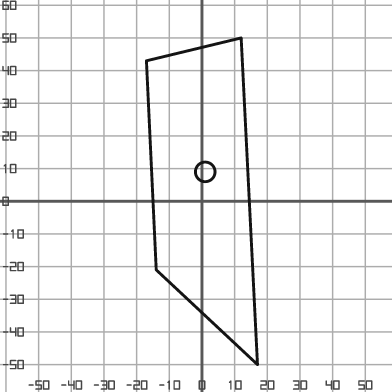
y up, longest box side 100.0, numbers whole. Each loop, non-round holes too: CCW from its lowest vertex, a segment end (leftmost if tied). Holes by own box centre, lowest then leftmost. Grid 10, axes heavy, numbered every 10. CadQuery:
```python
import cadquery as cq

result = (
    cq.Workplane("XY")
    .moveTo(17.0, -50.0)
    .lineTo(12.0, 50.0)
    .lineTo(-17.0, 43.0)
    .lineTo(-14.0, -21.0)
    .close()
    .moveTo(1.0, 9.0)
    .circle(3.0)
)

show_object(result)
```